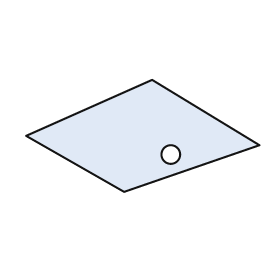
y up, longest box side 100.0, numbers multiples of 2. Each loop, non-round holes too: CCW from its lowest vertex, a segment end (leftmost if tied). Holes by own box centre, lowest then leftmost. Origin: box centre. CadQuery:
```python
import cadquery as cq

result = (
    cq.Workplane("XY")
    .moveTo(-8.0, -24.0)
    .lineTo(50.0, -4.0)
    .lineTo(4.0, 24.0)
    .lineTo(-50.0, 0.0)
    .close()
    .moveTo(12.0, -8.0)
    .circle(4.0)
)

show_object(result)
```